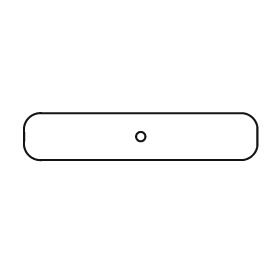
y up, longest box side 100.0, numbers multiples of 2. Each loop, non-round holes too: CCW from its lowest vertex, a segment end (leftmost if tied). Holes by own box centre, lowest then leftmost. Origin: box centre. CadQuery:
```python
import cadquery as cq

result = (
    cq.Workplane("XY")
    .moveTo(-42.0, -10.0)
    .lineTo(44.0, -10.0)
    .threePointArc((48.0, -8.0), (50.0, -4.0))
    .lineTo(50.0, 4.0)
    .threePointArc((48.0, 8.0), (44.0, 10.0))
    .lineTo(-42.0, 10.0)
    .threePointArc((-48.0, 8.0), (-50.0, 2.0))
    .lineTo(-50.0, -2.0)
    .threePointArc((-48.0, -8.0), (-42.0, -10.0))
    .close()
    .moveTo(0.0, 0.0)
    .circle(2.0)
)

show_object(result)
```